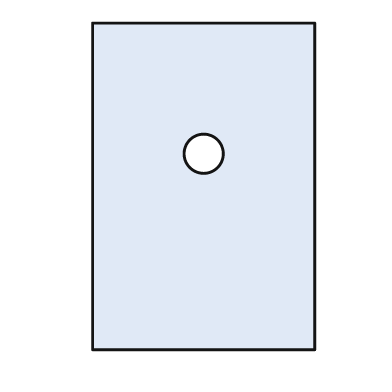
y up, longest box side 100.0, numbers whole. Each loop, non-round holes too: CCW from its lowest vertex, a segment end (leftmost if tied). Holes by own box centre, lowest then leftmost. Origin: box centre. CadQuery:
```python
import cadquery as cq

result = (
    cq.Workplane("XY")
    .moveTo(-34.0, -50.0)
    .lineTo(34.0, -50.0)
    .lineTo(34.0, 50.0)
    .lineTo(-34.0, 50.0)
    .close()
    .moveTo(0.0, 10.0)
    .circle(6.0)
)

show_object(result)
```